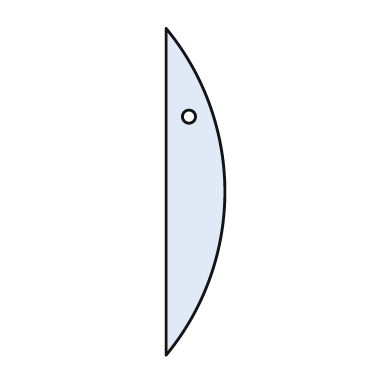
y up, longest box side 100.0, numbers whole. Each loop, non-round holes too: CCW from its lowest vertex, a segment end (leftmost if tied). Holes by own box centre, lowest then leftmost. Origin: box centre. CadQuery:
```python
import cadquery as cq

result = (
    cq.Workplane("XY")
    .moveTo(-9.0, -50.0)
    .threePointArc((9.0, 0.0), (-9.0, 50.0))
    .close()
    .moveTo(-2.0, 23.0)
    .circle(2.0)
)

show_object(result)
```